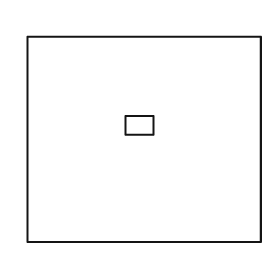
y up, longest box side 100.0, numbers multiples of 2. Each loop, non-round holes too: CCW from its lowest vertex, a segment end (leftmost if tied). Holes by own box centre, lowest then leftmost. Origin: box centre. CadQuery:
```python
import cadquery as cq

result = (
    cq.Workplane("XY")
    .moveTo(-50.0, -44.0)
    .lineTo(50.0, -44.0)
    .lineTo(50.0, 44.0)
    .lineTo(-50.0, 44.0)
    .close()
    .moveTo(-8.0, 2.0)
    .lineTo(4.0, 2.0)
    .lineTo(4.0, 10.0)
    .lineTo(-8.0, 10.0)
    .close()
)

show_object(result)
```